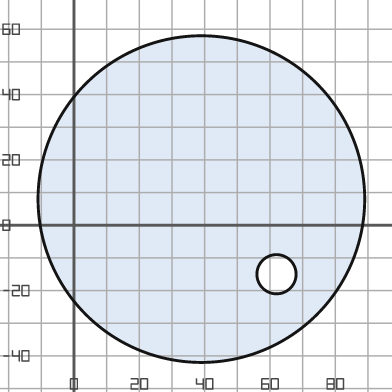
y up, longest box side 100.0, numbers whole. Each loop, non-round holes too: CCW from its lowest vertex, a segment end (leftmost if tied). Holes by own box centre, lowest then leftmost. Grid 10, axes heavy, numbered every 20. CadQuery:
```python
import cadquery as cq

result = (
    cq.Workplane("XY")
    .moveTo(39.0, 8.0)
    .circle(50.0)
    .moveTo(62.0, -15.0)
    .circle(6.0)
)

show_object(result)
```